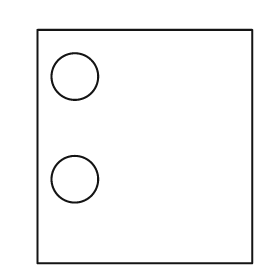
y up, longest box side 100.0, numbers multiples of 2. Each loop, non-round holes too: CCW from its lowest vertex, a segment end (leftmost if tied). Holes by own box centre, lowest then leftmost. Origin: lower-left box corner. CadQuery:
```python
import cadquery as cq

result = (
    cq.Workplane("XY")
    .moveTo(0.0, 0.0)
    .lineTo(92.0, 0.0)
    .lineTo(92.0, 100.0)
    .lineTo(0.0, 100.0)
    .close()
    .moveTo(16.0, 36.0)
    .circle(10.0)
    .moveTo(16.0, 80.0)
    .circle(10.0)
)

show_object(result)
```